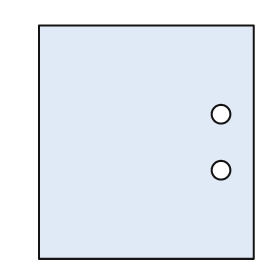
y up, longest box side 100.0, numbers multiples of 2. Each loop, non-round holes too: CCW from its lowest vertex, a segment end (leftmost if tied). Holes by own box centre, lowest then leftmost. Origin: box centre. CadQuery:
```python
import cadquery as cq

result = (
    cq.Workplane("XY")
    .moveTo(-46.0, -50.0)
    .lineTo(46.0, -50.0)
    .lineTo(46.0, 50.0)
    .lineTo(-46.0, 50.0)
    .close()
    .moveTo(32.0, -12.0)
    .circle(4.0)
    .moveTo(32.0, 12.0)
    .circle(4.0)
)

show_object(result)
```